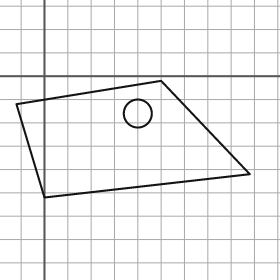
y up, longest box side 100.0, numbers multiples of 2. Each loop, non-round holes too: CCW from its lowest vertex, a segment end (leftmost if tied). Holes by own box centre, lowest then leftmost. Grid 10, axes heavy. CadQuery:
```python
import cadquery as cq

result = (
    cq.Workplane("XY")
    .moveTo(0.0, -52.0)
    .lineTo(88.0, -42.0)
    .lineTo(50.0, -2.0)
    .lineTo(-12.0, -12.0)
    .close()
    .moveTo(40.0, -16.0)
    .circle(6.0)
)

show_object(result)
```